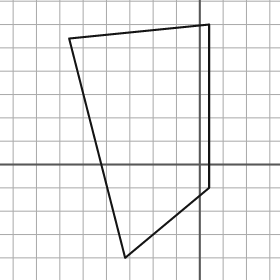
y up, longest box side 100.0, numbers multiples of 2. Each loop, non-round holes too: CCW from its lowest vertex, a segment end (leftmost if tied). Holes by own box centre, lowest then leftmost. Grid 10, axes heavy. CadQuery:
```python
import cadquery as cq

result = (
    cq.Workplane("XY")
    .moveTo(-32.0, -40.0)
    .lineTo(4.0, -10.0)
    .lineTo(4.0, 60.0)
    .lineTo(-56.0, 54.0)
    .close()
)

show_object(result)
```